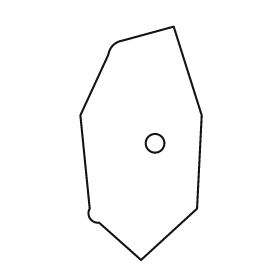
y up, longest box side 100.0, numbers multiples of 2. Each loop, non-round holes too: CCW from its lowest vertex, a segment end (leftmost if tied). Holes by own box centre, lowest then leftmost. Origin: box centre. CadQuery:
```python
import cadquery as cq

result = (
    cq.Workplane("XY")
    .moveTo(0.0, -50.0)
    .lineTo(24.0, -28.0)
    .lineTo(26.0, 12.0)
    .lineTo(14.0, 50.0)
    .lineTo(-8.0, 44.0)
    .threePointArc((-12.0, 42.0), (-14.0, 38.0))
    .lineTo(-26.0, 12.0)
    .lineTo(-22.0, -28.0)
    .threePointArc((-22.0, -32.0), (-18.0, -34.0))
    .close()
    .moveTo(6.0, 0.0)
    .circle(4.0)
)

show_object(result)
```